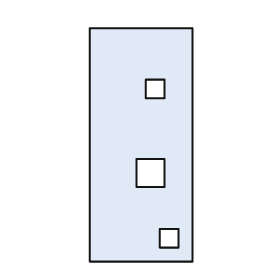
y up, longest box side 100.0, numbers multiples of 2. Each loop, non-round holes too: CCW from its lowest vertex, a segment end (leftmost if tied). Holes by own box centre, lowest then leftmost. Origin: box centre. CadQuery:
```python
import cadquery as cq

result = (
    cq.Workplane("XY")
    .moveTo(-22.0, -50.0)
    .lineTo(22.0, -50.0)
    .lineTo(22.0, 50.0)
    .lineTo(-22.0, 50.0)
    .close()
    .moveTo(8.0, -44.0)
    .lineTo(16.0, -44.0)
    .lineTo(16.0, -36.0)
    .lineTo(8.0, -36.0)
    .close()
    .moveTo(-2.0, -18.0)
    .lineTo(10.0, -18.0)
    .lineTo(10.0, -6.0)
    .lineTo(-2.0, -6.0)
    .close()
    .moveTo(2.0, 20.0)
    .lineTo(10.0, 20.0)
    .lineTo(10.0, 28.0)
    .lineTo(2.0, 28.0)
    .close()
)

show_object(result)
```